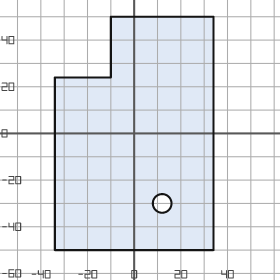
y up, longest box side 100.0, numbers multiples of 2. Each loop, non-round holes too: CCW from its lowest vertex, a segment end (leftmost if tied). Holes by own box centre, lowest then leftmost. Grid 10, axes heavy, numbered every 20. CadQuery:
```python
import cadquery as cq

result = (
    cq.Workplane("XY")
    .moveTo(-34.0, -50.0)
    .lineTo(34.0, -50.0)
    .lineTo(34.0, 50.0)
    .lineTo(-10.0, 50.0)
    .lineTo(-10.0, 24.0)
    .lineTo(-34.0, 24.0)
    .close()
    .moveTo(12.0, -30.0)
    .circle(4.0)
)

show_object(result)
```